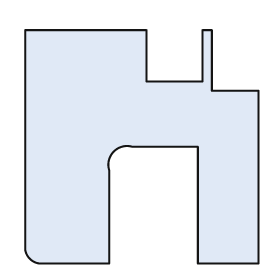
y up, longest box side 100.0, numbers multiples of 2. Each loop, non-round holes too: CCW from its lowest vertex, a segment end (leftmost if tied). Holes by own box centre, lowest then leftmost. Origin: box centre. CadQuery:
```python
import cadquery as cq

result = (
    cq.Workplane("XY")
    .moveTo(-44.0, -50.0)
    .lineTo(-14.0, -50.0)
    .lineTo(-14.0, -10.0)
    .threePointArc((-12.0, -2.0), (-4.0, 0.0))
    .lineTo(24.0, 0.0)
    .lineTo(24.0, -50.0)
    .lineTo(50.0, -50.0)
    .lineTo(50.0, 24.0)
    .lineTo(30.0, 24.0)
    .lineTo(30.0, 50.0)
    .lineTo(26.0, 50.0)
    .lineTo(26.0, 28.0)
    .lineTo(2.0, 28.0)
    .lineTo(2.0, 50.0)
    .lineTo(-50.0, 50.0)
    .lineTo(-50.0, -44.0)
    .threePointArc((-48.0, -48.0), (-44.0, -50.0))
    .close()
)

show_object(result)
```